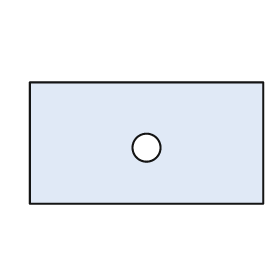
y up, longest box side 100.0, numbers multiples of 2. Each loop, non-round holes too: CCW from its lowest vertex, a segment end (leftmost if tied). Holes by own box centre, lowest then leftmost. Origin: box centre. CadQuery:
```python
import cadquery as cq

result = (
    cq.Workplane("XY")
    .moveTo(-50.0, -26.0)
    .lineTo(50.0, -26.0)
    .lineTo(50.0, 26.0)
    .lineTo(-50.0, 26.0)
    .close()
    .moveTo(0.0, -2.0)
    .circle(6.0)
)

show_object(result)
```